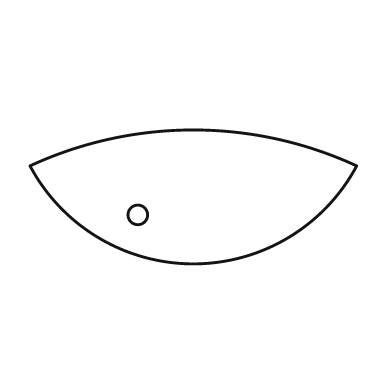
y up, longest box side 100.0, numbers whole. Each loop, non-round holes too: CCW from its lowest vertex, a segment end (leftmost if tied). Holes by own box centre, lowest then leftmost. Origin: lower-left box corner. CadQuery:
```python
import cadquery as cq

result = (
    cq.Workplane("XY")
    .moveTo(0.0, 30.0)
    .threePointArc((50.0, 0.0), (100.0, 30.0))
    .threePointArc((50.0, 41.0), (0.0, 30.0))
    .close()
    .moveTo(33.0, 15.0)
    .circle(3.0)
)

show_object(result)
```